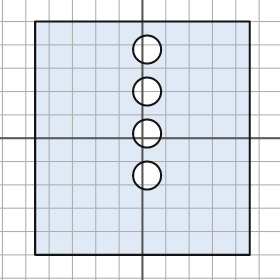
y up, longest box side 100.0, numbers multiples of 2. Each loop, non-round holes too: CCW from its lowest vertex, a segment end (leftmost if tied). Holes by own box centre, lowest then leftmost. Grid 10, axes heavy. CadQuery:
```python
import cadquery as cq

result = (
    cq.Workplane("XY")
    .moveTo(-46.0, -50.0)
    .lineTo(46.0, -50.0)
    .lineTo(46.0, 50.0)
    .lineTo(-46.0, 50.0)
    .close()
    .moveTo(2.0, -16.0)
    .circle(6.0)
    .moveTo(2.0, 2.0)
    .circle(6.0)
    .moveTo(2.0, 20.0)
    .circle(6.0)
    .moveTo(2.0, 38.0)
    .circle(6.0)
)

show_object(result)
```